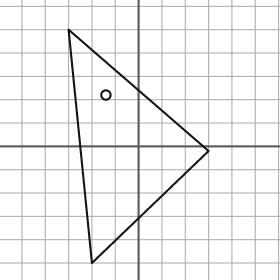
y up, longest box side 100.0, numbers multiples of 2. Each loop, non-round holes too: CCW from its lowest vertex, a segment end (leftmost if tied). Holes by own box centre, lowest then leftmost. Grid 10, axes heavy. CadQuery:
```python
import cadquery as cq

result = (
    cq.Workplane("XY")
    .moveTo(-20.0, -50.0)
    .lineTo(30.0, -2.0)
    .lineTo(-30.0, 50.0)
    .close()
    .moveTo(-14.0, 22.0)
    .circle(2.0)
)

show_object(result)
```